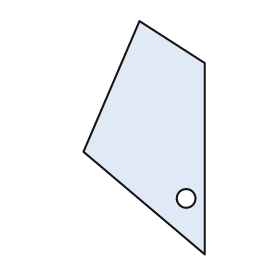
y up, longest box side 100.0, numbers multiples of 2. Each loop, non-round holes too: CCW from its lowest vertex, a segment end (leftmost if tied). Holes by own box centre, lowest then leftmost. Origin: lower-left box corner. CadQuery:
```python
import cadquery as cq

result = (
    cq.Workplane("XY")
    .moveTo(52.0, 0.0)
    .lineTo(52.0, 82.0)
    .lineTo(24.0, 100.0)
    .lineTo(0.0, 44.0)
    .close()
    .moveTo(44.0, 24.0)
    .circle(4.0)
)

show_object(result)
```